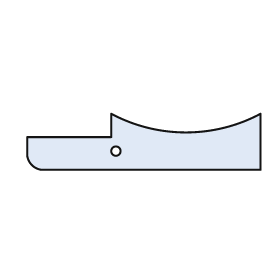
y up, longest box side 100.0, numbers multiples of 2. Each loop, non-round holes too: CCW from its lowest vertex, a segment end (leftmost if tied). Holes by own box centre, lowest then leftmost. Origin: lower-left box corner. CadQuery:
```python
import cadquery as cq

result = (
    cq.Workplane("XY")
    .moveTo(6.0, 0.0)
    .lineTo(100.0, 0.0)
    .lineTo(100.0, 24.0)
    .threePointArc((68.0, 16.0), (36.0, 24.0))
    .lineTo(36.0, 14.0)
    .lineTo(0.0, 14.0)
    .lineTo(0.0, 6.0)
    .threePointArc((2.0, 2.0), (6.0, 0.0))
    .close()
    .moveTo(38.0, 8.0)
    .circle(2.0)
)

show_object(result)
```